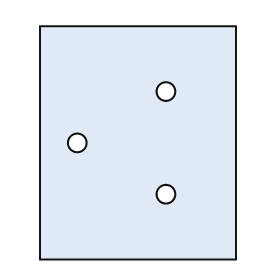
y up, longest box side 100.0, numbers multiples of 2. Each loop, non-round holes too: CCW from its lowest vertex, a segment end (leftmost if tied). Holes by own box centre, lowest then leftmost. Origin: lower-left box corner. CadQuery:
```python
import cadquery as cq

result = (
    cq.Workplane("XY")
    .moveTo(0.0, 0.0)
    .lineTo(84.0, 0.0)
    .lineTo(84.0, 100.0)
    .lineTo(0.0, 100.0)
    .close()
    .moveTo(54.0, 28.0)
    .circle(4.0)
    .moveTo(16.0, 50.0)
    .circle(4.0)
    .moveTo(54.0, 72.0)
    .circle(4.0)
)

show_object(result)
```